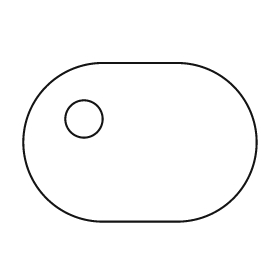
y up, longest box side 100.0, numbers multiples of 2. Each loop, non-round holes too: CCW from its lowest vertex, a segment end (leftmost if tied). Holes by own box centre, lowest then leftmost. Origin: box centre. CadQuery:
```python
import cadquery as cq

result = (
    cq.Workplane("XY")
    .moveTo(-16.0, -34.0)
    .lineTo(16.0, -34.0)
    .threePointArc((50.0, 0.0), (16.0, 34.0))
    .lineTo(-16.0, 34.0)
    .threePointArc((-50.0, 0.0), (-16.0, -34.0))
    .close()
    .moveTo(-24.0, 10.0)
    .circle(8.0)
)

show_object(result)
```